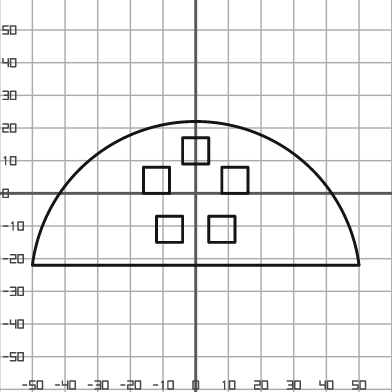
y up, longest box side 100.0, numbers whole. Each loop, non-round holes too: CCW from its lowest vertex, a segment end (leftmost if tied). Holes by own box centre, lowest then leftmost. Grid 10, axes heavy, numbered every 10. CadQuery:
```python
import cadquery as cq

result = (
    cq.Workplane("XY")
    .moveTo(-50.0, -22.0)
    .lineTo(50.0, -22.0)
    .threePointArc((0.0, 22.0), (-50.0, -22.0))
    .close()
    .moveTo(-12.0, -15.0)
    .lineTo(-4.0, -15.0)
    .lineTo(-4.0, -7.0)
    .lineTo(-12.0, -7.0)
    .close()
    .moveTo(4.0, -15.0)
    .lineTo(12.0, -15.0)
    .lineTo(12.0, -7.0)
    .lineTo(4.0, -7.0)
    .close()
    .moveTo(-16.0, 0.0)
    .lineTo(-8.0, 0.0)
    .lineTo(-8.0, 8.0)
    .lineTo(-16.0, 8.0)
    .close()
    .moveTo(8.0, 0.0)
    .lineTo(16.0, 0.0)
    .lineTo(16.0, 8.0)
    .lineTo(8.0, 8.0)
    .close()
    .moveTo(-4.0, 9.0)
    .lineTo(4.0, 9.0)
    .lineTo(4.0, 17.0)
    .lineTo(-4.0, 17.0)
    .close()
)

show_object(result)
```